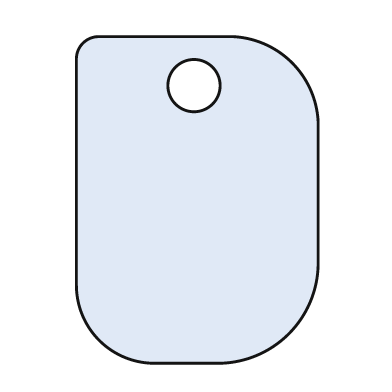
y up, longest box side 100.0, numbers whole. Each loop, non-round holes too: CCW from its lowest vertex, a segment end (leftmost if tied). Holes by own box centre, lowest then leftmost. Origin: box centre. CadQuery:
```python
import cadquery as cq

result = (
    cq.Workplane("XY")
    .moveTo(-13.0, -50.0)
    .lineTo(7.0, -50.0)
    .threePointArc((28.0, -41.0), (37.0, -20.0))
    .lineTo(37.0, 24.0)
    .threePointArc((29.0, 42.0), (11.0, 50.0))
    .lineTo(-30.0, 50.0)
    .threePointArc((-35.0, 48.0), (-37.0, 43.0))
    .lineTo(-37.0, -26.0)
    .threePointArc((-30.0, -43.0), (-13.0, -50.0))
    .close()
    .moveTo(-1.0, 35.0)
    .circle(8.0)
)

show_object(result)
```